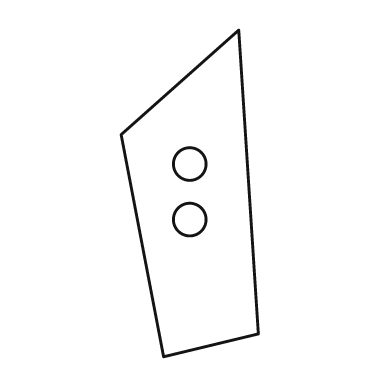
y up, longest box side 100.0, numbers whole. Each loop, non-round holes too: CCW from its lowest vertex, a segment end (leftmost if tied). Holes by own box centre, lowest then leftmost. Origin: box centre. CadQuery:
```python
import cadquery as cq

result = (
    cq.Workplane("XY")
    .moveTo(-8.0, -50.0)
    .lineTo(21.0, -43.0)
    .lineTo(15.0, 50.0)
    .lineTo(-21.0, 18.0)
    .close()
    .moveTo(0.0, -8.0)
    .circle(5.0)
    .moveTo(0.0, 9.0)
    .circle(5.0)
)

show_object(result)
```